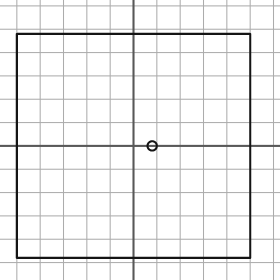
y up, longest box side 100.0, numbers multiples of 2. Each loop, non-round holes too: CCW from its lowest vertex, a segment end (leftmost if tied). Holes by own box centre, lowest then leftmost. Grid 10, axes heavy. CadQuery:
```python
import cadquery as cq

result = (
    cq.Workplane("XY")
    .moveTo(-50.0, -48.0)
    .lineTo(50.0, -48.0)
    .lineTo(50.0, 48.0)
    .lineTo(-50.0, 48.0)
    .close()
    .moveTo(8.0, 0.0)
    .circle(2.0)
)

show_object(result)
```